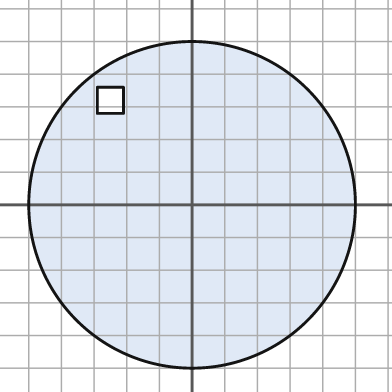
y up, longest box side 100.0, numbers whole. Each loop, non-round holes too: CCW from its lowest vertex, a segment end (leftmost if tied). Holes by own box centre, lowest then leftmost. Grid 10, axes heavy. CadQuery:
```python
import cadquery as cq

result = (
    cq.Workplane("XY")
    .moveTo(0.0, 0.0)
    .circle(50.0)
    .moveTo(-29.0, 28.0)
    .lineTo(-21.0, 28.0)
    .lineTo(-21.0, 36.0)
    .lineTo(-29.0, 36.0)
    .close()
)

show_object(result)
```